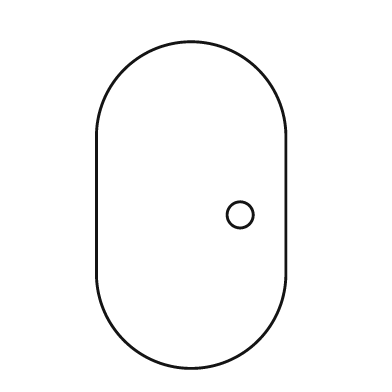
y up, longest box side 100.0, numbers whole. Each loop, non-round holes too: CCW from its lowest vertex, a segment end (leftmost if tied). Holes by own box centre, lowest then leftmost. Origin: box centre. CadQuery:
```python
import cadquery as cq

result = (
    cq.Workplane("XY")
    .moveTo(-29.0, -21.0)
    .threePointArc((0.0, -50.0), (29.0, -21.0))
    .lineTo(29.0, 21.0)
    .threePointArc((0.0, 50.0), (-29.0, 21.0))
    .close()
    .moveTo(15.0, -3.0)
    .circle(4.0)
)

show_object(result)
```